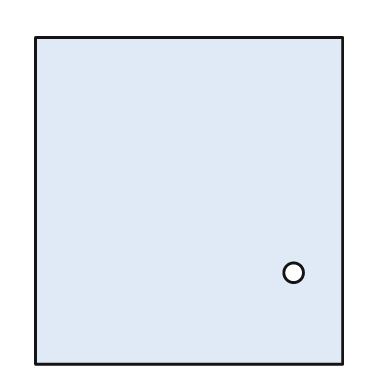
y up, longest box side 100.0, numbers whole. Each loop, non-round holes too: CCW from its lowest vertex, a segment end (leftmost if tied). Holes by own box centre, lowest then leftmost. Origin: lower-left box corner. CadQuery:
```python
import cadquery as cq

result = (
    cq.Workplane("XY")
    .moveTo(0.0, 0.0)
    .lineTo(94.0, 0.0)
    .lineTo(94.0, 100.0)
    .lineTo(0.0, 100.0)
    .close()
    .moveTo(79.0, 28.0)
    .circle(3.0)
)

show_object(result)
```